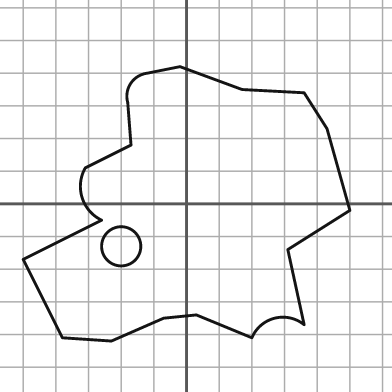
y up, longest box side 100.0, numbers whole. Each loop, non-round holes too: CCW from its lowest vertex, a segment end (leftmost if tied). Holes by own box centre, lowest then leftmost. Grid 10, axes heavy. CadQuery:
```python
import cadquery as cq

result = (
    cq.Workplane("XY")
    .moveTo(-23.0, -42.0)
    .lineTo(-7.0, -35.0)
    .lineTo(3.0, -34.0)
    .lineTo(20.0, -41.0)
    .threePointArc((27.0, -35.0), (36.0, -37.0))
    .lineTo(31.0, -14.0)
    .lineTo(50.0, -2.0)
    .lineTo(43.0, 23.0)
    .lineTo(36.0, 34.0)
    .lineTo(17.0, 35.0)
    .lineTo(-2.0, 42.0)
    .lineTo(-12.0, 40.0)
    .threePointArc((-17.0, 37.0), (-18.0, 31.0))
    .lineTo(-17.0, 18.0)
    .lineTo(-31.0, 11.0)
    .threePointArc((-32.0, 2.0), (-26.0, -5.0))
    .lineTo(-50.0, -17.0)
    .lineTo(-38.0, -41.0)
    .close()
    .moveTo(-20.0, -13.0)
    .circle(6.0)
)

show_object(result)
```